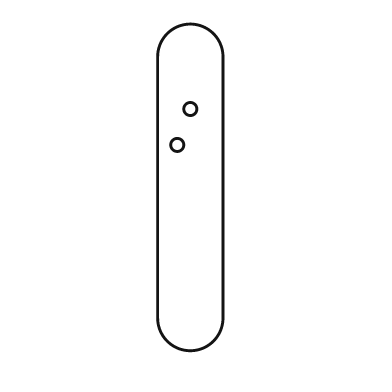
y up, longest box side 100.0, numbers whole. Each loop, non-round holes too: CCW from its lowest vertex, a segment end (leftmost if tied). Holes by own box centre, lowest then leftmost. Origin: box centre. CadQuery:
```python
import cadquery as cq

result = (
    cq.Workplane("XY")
    .moveTo(-10.0, -40.0)
    .threePointArc((0.0, -50.0), (10.0, -40.0))
    .lineTo(10.0, 40.0)
    .threePointArc((0.0, 50.0), (-10.0, 40.0))
    .close()
    .moveTo(-4.0, 13.0)
    .circle(2.0)
    .moveTo(0.0, 24.0)
    .circle(2.0)
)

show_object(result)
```